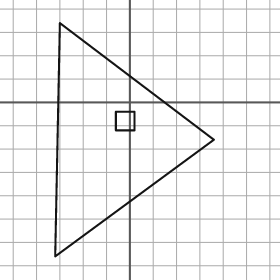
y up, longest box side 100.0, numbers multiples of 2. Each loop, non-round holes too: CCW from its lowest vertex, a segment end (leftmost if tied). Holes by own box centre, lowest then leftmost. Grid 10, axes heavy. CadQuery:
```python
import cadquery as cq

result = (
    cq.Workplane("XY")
    .moveTo(-32.0, -66.0)
    .lineTo(36.0, -16.0)
    .lineTo(-30.0, 34.0)
    .close()
    .moveTo(-6.0, -12.0)
    .lineTo(2.0, -12.0)
    .lineTo(2.0, -4.0)
    .lineTo(-6.0, -4.0)
    .close()
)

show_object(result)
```